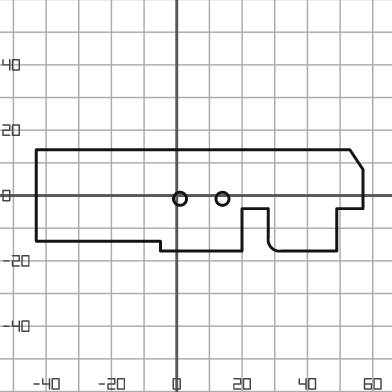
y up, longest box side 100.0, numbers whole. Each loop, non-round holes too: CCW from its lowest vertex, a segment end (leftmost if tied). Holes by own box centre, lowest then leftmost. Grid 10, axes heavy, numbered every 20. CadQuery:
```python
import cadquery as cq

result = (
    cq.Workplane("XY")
    .moveTo(-5.0, -17.0)
    .lineTo(20.0, -17.0)
    .lineTo(20.0, -4.0)
    .lineTo(28.0, -4.0)
    .lineTo(28.0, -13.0)
    .threePointArc((29.0, -16.0), (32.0, -17.0))
    .lineTo(49.0, -17.0)
    .lineTo(49.0, -4.0)
    .lineTo(57.0, -4.0)
    .lineTo(57.0, 8.0)
    .lineTo(53.0, 14.0)
    .lineTo(-43.0, 14.0)
    .lineTo(-43.0, -14.0)
    .lineTo(-5.0, -14.0)
    .close()
    .moveTo(1.0, -1.0)
    .circle(2.0)
    .moveTo(14.0, -1.0)
    .circle(2.0)
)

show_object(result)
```